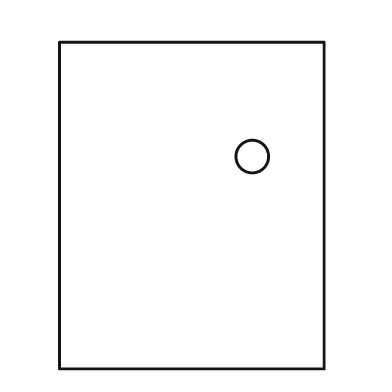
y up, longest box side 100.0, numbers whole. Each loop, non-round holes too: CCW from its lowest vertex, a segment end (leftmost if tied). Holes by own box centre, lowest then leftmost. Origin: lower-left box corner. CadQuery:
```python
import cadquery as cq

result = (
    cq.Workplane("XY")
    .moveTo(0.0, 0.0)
    .lineTo(81.0, 0.0)
    .lineTo(81.0, 100.0)
    .lineTo(0.0, 100.0)
    .close()
    .moveTo(59.0, 65.0)
    .circle(5.0)
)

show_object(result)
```